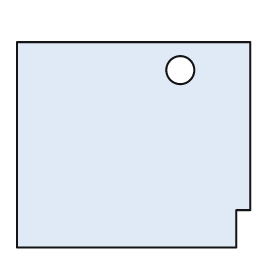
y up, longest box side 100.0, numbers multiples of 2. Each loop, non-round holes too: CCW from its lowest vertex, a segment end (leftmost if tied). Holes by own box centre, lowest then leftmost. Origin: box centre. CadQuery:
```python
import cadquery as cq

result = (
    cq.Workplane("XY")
    .moveTo(-50.0, -44.0)
    .lineTo(44.0, -44.0)
    .lineTo(44.0, -28.0)
    .lineTo(50.0, -28.0)
    .lineTo(50.0, 44.0)
    .lineTo(-50.0, 44.0)
    .close()
    .moveTo(20.0, 32.0)
    .circle(6.0)
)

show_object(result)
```